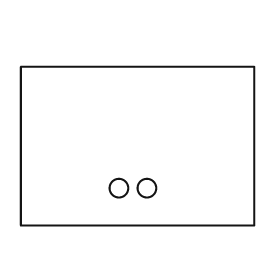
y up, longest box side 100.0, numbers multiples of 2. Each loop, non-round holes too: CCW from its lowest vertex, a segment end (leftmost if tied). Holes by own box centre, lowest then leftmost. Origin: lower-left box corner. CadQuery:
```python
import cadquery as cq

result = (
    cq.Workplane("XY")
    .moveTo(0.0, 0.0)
    .lineTo(100.0, 0.0)
    .lineTo(100.0, 68.0)
    .lineTo(0.0, 68.0)
    .close()
    .moveTo(42.0, 16.0)
    .circle(4.0)
    .moveTo(54.0, 16.0)
    .circle(4.0)
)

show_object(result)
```